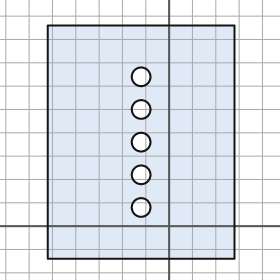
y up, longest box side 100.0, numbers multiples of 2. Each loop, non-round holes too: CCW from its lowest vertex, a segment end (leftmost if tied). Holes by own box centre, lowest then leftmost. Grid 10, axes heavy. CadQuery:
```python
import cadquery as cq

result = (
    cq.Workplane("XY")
    .moveTo(-52.0, -14.0)
    .lineTo(28.0, -14.0)
    .lineTo(28.0, 86.0)
    .lineTo(-52.0, 86.0)
    .close()
    .moveTo(-12.0, 8.0)
    .circle(4.0)
    .moveTo(-12.0, 22.0)
    .circle(4.0)
    .moveTo(-12.0, 36.0)
    .circle(4.0)
    .moveTo(-12.0, 50.0)
    .circle(4.0)
    .moveTo(-12.0, 64.0)
    .circle(4.0)
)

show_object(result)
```